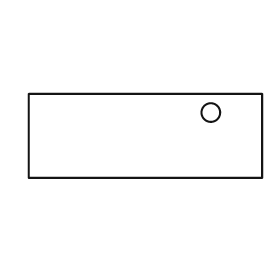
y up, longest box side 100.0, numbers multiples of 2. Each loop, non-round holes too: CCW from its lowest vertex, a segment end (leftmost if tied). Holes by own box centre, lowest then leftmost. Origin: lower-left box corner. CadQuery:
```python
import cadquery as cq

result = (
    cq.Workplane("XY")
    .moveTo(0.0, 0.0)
    .lineTo(100.0, 0.0)
    .lineTo(100.0, 36.0)
    .lineTo(0.0, 36.0)
    .close()
    .moveTo(78.0, 28.0)
    .circle(4.0)
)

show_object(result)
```